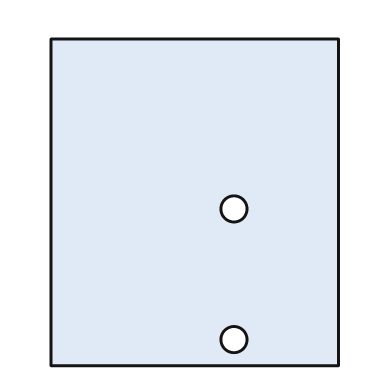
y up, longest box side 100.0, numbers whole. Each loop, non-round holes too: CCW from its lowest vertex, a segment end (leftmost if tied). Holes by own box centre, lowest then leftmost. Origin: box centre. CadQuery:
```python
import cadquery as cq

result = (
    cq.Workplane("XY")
    .moveTo(-44.0, -50.0)
    .lineTo(44.0, -50.0)
    .lineTo(44.0, 50.0)
    .lineTo(-44.0, 50.0)
    .close()
    .moveTo(12.0, -42.0)
    .circle(4.0)
    .moveTo(12.0, -2.0)
    .circle(4.0)
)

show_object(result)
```